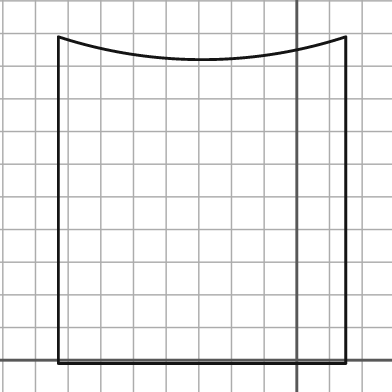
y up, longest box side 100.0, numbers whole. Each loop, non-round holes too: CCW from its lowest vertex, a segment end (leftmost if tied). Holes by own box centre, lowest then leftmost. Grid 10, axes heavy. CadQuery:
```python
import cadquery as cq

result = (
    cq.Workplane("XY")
    .moveTo(-73.0, -1.0)
    .lineTo(15.0, -1.0)
    .lineTo(15.0, 99.0)
    .threePointArc((-29.0, 92.0), (-73.0, 99.0))
    .close()
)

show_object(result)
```